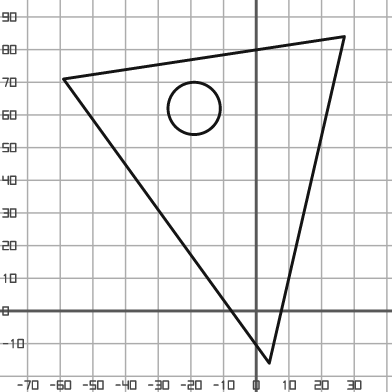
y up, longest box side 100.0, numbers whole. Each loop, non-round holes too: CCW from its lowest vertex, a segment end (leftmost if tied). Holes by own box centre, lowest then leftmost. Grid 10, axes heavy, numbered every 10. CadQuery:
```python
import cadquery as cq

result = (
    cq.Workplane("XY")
    .moveTo(4.0, -16.0)
    .lineTo(27.0, 84.0)
    .lineTo(-59.0, 71.0)
    .close()
    .moveTo(-19.0, 62.0)
    .circle(8.0)
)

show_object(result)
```